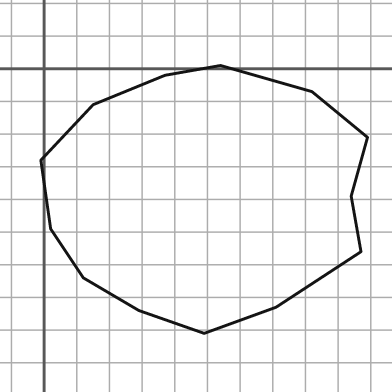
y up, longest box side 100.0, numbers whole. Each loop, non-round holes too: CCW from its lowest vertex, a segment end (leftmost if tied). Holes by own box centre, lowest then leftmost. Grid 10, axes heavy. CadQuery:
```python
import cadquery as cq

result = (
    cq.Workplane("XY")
    .moveTo(49.0, -81.0)
    .lineTo(71.0, -73.0)
    .lineTo(97.0, -56.0)
    .lineTo(94.0, -39.0)
    .lineTo(99.0, -21.0)
    .lineTo(82.0, -7.0)
    .lineTo(54.0, 1.0)
    .lineTo(37.0, -2.0)
    .lineTo(15.0, -11.0)
    .lineTo(-1.0, -28.0)
    .lineTo(2.0, -49.0)
    .lineTo(12.0, -64.0)
    .lineTo(29.0, -74.0)
    .close()
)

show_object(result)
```